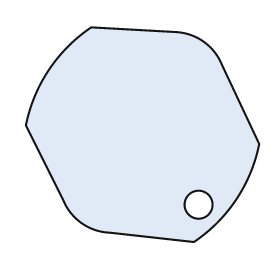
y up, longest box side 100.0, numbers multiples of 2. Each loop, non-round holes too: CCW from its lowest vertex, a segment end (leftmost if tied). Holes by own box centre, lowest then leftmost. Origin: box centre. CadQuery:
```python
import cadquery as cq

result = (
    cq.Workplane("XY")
    .moveTo(22.0, -46.0)
    .threePointArc((40.0, -28.0), (50.0, -4.0))
    .lineTo(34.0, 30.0)
    .threePointArc((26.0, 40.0), (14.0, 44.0))
    .lineTo(-22.0, 46.0)
    .threePointArc((-40.0, 28.0), (-50.0, 4.0))
    .lineTo(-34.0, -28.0)
    .threePointArc((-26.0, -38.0), (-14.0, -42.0))
    .close()
    .moveTo(24.0, -30.0)
    .circle(6.0)
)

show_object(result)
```